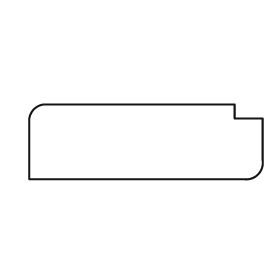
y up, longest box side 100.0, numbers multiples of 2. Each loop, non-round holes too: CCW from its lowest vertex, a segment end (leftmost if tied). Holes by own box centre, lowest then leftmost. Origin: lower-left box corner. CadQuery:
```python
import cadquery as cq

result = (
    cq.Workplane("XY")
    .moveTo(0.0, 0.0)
    .lineTo(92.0, 0.0)
    .threePointArc((98.0, 2.0), (100.0, 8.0))
    .lineTo(100.0, 26.0)
    .lineTo(88.0, 26.0)
    .lineTo(88.0, 32.0)
    .lineTo(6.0, 32.0)
    .threePointArc((2.0, 30.0), (0.0, 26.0))
    .close()
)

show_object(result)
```